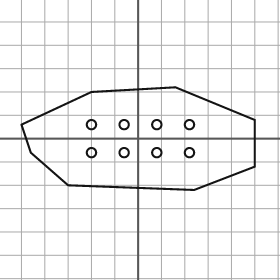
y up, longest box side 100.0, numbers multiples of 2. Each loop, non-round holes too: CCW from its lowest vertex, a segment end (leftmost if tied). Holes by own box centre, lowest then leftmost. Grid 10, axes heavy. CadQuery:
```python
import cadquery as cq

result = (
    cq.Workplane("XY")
    .moveTo(24.0, -22.0)
    .lineTo(50.0, -12.0)
    .lineTo(50.0, 8.0)
    .lineTo(16.0, 22.0)
    .lineTo(-20.0, 20.0)
    .lineTo(-50.0, 6.0)
    .lineTo(-46.0, -6.0)
    .lineTo(-30.0, -20.0)
    .close()
    .moveTo(-20.0, -6.0)
    .circle(2.0)
    .moveTo(-6.0, -6.0)
    .circle(2.0)
    .moveTo(8.0, -6.0)
    .circle(2.0)
    .moveTo(22.0, -6.0)
    .circle(2.0)
    .moveTo(-20.0, 6.0)
    .circle(2.0)
    .moveTo(-6.0, 6.0)
    .circle(2.0)
    .moveTo(8.0, 6.0)
    .circle(2.0)
    .moveTo(22.0, 6.0)
    .circle(2.0)
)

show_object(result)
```